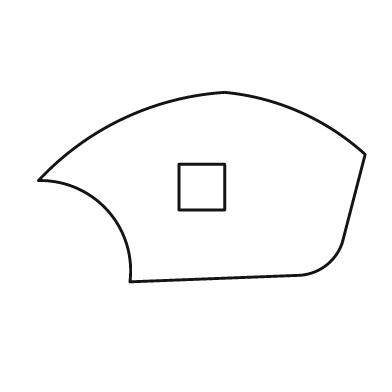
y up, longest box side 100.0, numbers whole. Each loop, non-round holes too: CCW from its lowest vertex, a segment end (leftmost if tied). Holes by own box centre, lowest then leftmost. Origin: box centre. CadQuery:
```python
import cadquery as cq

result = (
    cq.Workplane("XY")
    .moveTo(-22.0, -29.0)
    .lineTo(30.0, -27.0)
    .threePointArc((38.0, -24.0), (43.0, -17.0))
    .lineTo(50.0, 10.0)
    .threePointArc((30.0, 23.0), (7.0, 29.0))
    .threePointArc((-24.0, 21.0), (-50.0, 2.0))
    .threePointArc((-29.0, -7.0), (-22.0, -29.0))
    .close()
    .moveTo(-7.0, -7.0)
    .lineTo(7.0, -7.0)
    .lineTo(7.0, 7.0)
    .lineTo(-7.0, 7.0)
    .close()
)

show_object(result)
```